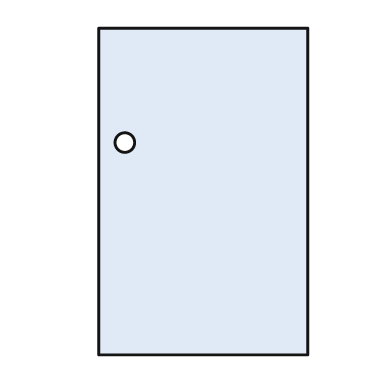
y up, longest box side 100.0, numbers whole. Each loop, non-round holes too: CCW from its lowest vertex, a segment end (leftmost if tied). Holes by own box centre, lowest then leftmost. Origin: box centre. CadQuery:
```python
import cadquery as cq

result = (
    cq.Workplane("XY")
    .moveTo(-32.0, -50.0)
    .lineTo(32.0, -50.0)
    .lineTo(32.0, 50.0)
    .lineTo(-32.0, 50.0)
    .close()
    .moveTo(-24.0, 15.0)
    .circle(3.0)
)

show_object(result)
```